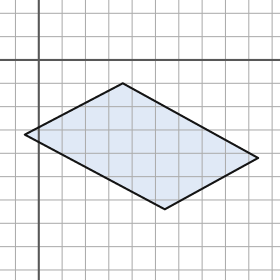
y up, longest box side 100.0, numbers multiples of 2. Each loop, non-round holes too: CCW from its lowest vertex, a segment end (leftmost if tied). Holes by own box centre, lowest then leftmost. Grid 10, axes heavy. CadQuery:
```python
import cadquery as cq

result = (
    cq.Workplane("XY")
    .moveTo(54.0, -64.0)
    .lineTo(94.0, -42.0)
    .lineTo(36.0, -10.0)
    .lineTo(-6.0, -32.0)
    .close()
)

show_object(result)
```